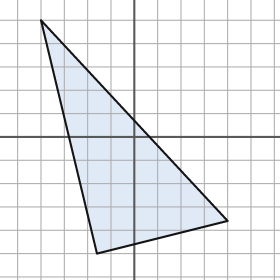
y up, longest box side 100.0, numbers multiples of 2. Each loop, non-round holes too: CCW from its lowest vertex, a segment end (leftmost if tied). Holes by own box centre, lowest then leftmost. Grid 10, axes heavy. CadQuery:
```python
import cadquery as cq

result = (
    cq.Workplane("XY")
    .moveTo(-16.0, -50.0)
    .lineTo(40.0, -36.0)
    .lineTo(-40.0, 50.0)
    .close()
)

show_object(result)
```